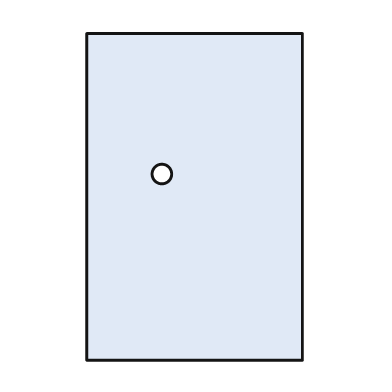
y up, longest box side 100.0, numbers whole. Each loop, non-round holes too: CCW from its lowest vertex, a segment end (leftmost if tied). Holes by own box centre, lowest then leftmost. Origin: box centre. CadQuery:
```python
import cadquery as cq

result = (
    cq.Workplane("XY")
    .moveTo(-33.0, -50.0)
    .lineTo(33.0, -50.0)
    .lineTo(33.0, 50.0)
    .lineTo(-33.0, 50.0)
    .close()
    .moveTo(-10.0, 7.0)
    .circle(3.0)
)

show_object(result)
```